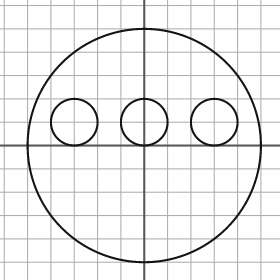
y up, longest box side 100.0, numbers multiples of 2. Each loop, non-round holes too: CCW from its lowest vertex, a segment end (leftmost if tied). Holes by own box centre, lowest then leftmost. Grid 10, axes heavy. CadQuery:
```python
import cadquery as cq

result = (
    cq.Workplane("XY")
    .moveTo(0.0, 0.0)
    .circle(50.0)
    .moveTo(-30.0, 10.0)
    .circle(10.0)
    .moveTo(0.0, 10.0)
    .circle(10.0)
    .moveTo(30.0, 10.0)
    .circle(10.0)
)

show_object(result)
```